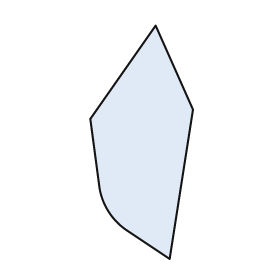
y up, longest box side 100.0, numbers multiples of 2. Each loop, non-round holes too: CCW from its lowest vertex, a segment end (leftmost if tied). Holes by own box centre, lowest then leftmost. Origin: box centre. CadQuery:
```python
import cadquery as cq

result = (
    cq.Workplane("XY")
    .moveTo(12.0, -50.0)
    .lineTo(22.0, 14.0)
    .lineTo(6.0, 50.0)
    .lineTo(-22.0, 10.0)
    .lineTo(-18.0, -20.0)
    .threePointArc((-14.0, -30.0), (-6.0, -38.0))
    .close()
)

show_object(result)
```